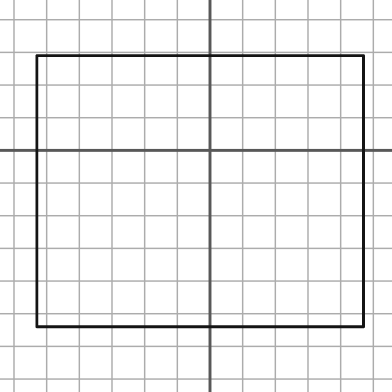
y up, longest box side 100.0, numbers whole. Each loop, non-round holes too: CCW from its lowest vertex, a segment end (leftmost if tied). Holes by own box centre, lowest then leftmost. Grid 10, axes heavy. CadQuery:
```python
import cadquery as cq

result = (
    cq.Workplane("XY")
    .moveTo(-53.0, -54.0)
    .lineTo(47.0, -54.0)
    .lineTo(47.0, 29.0)
    .lineTo(-53.0, 29.0)
    .close()
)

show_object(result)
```